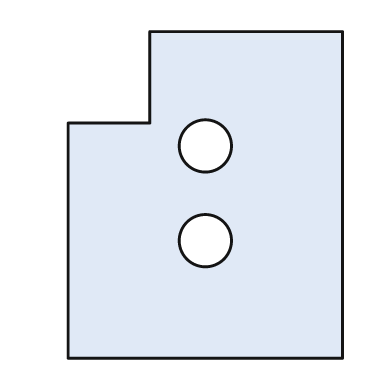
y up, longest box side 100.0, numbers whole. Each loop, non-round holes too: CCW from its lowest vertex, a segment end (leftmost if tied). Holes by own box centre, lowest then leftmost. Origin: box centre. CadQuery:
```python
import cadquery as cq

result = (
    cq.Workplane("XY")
    .moveTo(-42.0, -50.0)
    .lineTo(42.0, -50.0)
    .lineTo(42.0, 50.0)
    .lineTo(-17.0, 50.0)
    .lineTo(-17.0, 22.0)
    .lineTo(-42.0, 22.0)
    .close()
    .moveTo(0.0, -14.0)
    .circle(8.0)
    .moveTo(0.0, 15.0)
    .circle(8.0)
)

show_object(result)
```